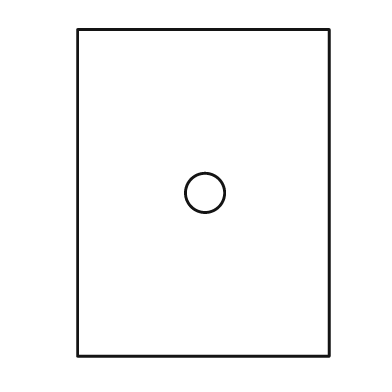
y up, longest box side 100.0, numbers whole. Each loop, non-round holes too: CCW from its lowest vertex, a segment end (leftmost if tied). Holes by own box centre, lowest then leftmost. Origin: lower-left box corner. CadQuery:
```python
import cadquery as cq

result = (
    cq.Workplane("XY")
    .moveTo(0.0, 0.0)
    .lineTo(77.0, 0.0)
    .lineTo(77.0, 100.0)
    .lineTo(0.0, 100.0)
    .close()
    .moveTo(39.0, 50.0)
    .circle(6.0)
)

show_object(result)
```